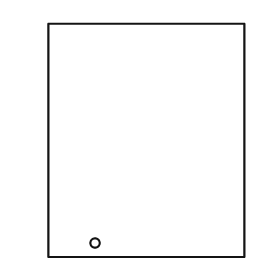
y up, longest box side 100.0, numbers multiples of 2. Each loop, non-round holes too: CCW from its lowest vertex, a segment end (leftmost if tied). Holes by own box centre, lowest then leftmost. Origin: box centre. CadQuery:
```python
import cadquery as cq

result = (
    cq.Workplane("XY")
    .moveTo(-42.0, -50.0)
    .lineTo(42.0, -50.0)
    .lineTo(42.0, 50.0)
    .lineTo(-42.0, 50.0)
    .close()
    .moveTo(-22.0, -44.0)
    .circle(2.0)
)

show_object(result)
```